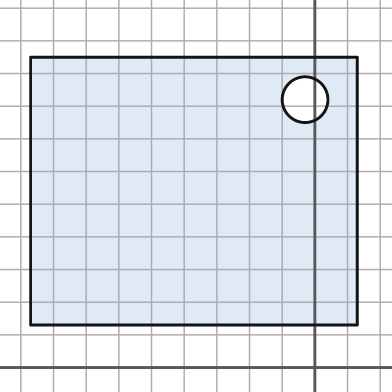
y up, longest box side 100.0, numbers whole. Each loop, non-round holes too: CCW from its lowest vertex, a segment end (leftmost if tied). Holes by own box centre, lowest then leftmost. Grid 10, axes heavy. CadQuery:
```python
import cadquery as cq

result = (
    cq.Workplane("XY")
    .moveTo(-87.0, 13.0)
    .lineTo(13.0, 13.0)
    .lineTo(13.0, 95.0)
    .lineTo(-87.0, 95.0)
    .close()
    .moveTo(-3.0, 82.0)
    .circle(7.0)
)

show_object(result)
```